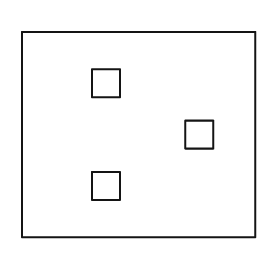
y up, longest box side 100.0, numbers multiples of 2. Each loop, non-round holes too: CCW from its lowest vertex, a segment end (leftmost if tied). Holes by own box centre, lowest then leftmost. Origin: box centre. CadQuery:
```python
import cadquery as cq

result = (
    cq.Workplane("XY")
    .moveTo(-50.0, -44.0)
    .lineTo(50.0, -44.0)
    .lineTo(50.0, 44.0)
    .lineTo(-50.0, 44.0)
    .close()
    .moveTo(-20.0, -28.0)
    .lineTo(-8.0, -28.0)
    .lineTo(-8.0, -16.0)
    .lineTo(-20.0, -16.0)
    .close()
    .moveTo(20.0, -6.0)
    .lineTo(32.0, -6.0)
    .lineTo(32.0, 6.0)
    .lineTo(20.0, 6.0)
    .close()
    .moveTo(-20.0, 16.0)
    .lineTo(-8.0, 16.0)
    .lineTo(-8.0, 28.0)
    .lineTo(-20.0, 28.0)
    .close()
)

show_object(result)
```